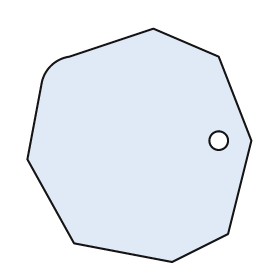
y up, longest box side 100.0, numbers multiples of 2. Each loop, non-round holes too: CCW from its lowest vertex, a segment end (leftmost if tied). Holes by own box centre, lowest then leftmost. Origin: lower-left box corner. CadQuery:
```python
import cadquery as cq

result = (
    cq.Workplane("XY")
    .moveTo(62.0, 0.0)
    .lineTo(86.0, 12.0)
    .lineTo(96.0, 52.0)
    .lineTo(82.0, 88.0)
    .lineTo(54.0, 100.0)
    .lineTo(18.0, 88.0)
    .threePointArc((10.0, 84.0), (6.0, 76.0))
    .lineTo(0.0, 44.0)
    .lineTo(20.0, 8.0)
    .close()
    .moveTo(82.0, 52.0)
    .circle(4.0)
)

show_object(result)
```